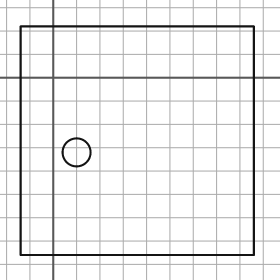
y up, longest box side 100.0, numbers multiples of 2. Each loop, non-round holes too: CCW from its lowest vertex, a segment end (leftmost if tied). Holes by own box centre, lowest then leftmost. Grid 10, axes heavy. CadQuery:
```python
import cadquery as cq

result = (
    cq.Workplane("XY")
    .moveTo(-14.0, -76.0)
    .lineTo(86.0, -76.0)
    .lineTo(86.0, 22.0)
    .lineTo(-14.0, 22.0)
    .close()
    .moveTo(10.0, -32.0)
    .circle(6.0)
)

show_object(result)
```